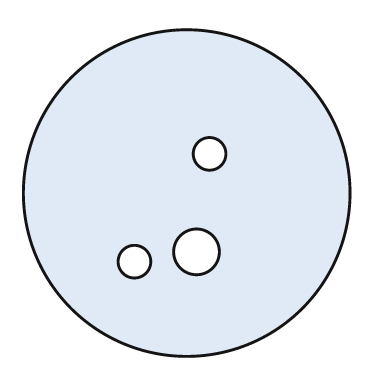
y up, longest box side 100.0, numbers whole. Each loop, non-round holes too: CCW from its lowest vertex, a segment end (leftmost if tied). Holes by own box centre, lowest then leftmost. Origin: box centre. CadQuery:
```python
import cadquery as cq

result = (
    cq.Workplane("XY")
    .moveTo(0.0, 0.0)
    .circle(50.0)
    .moveTo(-16.0, -21.0)
    .circle(5.0)
    .moveTo(3.0, -18.0)
    .circle(7.0)
    .moveTo(7.0, 12.0)
    .circle(5.0)
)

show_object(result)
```